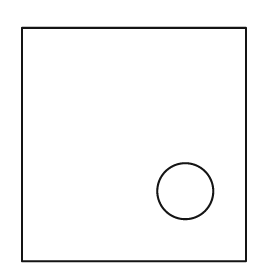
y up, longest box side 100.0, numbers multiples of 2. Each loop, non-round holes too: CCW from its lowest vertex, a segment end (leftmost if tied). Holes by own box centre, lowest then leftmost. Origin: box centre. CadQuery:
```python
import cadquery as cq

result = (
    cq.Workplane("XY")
    .moveTo(-48.0, -50.0)
    .lineTo(48.0, -50.0)
    .lineTo(48.0, 50.0)
    .lineTo(-48.0, 50.0)
    .close()
    .moveTo(22.0, -20.0)
    .circle(12.0)
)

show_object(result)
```